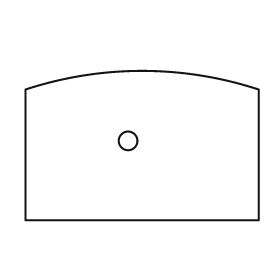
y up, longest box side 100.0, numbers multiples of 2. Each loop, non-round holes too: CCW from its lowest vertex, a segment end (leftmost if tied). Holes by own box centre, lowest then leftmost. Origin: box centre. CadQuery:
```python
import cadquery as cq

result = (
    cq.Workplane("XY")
    .moveTo(-50.0, -32.0)
    .lineTo(50.0, -32.0)
    .lineTo(50.0, 24.0)
    .threePointArc((0.0, 32.0), (-50.0, 24.0))
    .close()
    .moveTo(-6.0, 2.0)
    .circle(4.0)
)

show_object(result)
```